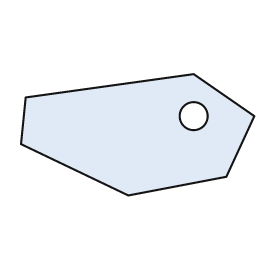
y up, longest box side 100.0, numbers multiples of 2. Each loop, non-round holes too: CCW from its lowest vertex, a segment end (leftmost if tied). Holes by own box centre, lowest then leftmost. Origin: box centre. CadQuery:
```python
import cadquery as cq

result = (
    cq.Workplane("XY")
    .moveTo(-4.0, -26.0)
    .lineTo(38.0, -18.0)
    .lineTo(50.0, 8.0)
    .lineTo(24.0, 26.0)
    .lineTo(-48.0, 16.0)
    .lineTo(-50.0, -4.0)
    .close()
    .moveTo(24.0, 8.0)
    .circle(6.0)
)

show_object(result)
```